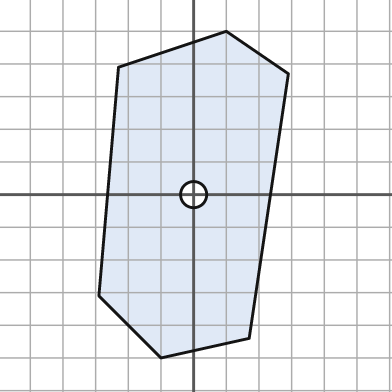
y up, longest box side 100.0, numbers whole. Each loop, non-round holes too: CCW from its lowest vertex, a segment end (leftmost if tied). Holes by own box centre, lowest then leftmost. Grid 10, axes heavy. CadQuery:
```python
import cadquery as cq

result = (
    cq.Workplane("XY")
    .moveTo(-10.0, -50.0)
    .lineTo(17.0, -44.0)
    .lineTo(29.0, 37.0)
    .lineTo(10.0, 50.0)
    .lineTo(-23.0, 39.0)
    .lineTo(-29.0, -31.0)
    .close()
    .moveTo(0.0, 0.0)
    .circle(4.0)
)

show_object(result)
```